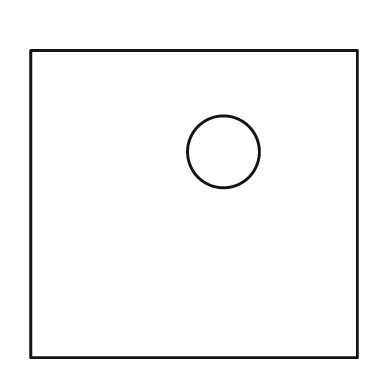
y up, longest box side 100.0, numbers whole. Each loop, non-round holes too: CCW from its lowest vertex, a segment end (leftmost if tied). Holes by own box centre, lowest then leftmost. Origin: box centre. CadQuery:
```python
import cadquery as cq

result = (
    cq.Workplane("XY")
    .moveTo(-50.0, -47.0)
    .lineTo(50.0, -47.0)
    .lineTo(50.0, 47.0)
    .lineTo(-50.0, 47.0)
    .close()
    .moveTo(9.0, 16.0)
    .circle(11.0)
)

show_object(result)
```